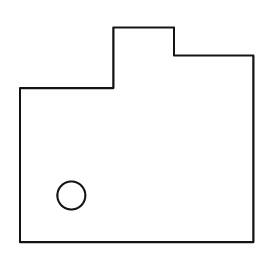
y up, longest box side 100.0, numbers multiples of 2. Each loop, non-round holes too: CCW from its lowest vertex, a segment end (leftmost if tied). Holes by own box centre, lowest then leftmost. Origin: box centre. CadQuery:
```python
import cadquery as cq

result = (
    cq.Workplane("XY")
    .moveTo(-50.0, -46.0)
    .lineTo(50.0, -46.0)
    .lineTo(50.0, 34.0)
    .lineTo(16.0, 34.0)
    .lineTo(16.0, 46.0)
    .lineTo(-10.0, 46.0)
    .lineTo(-10.0, 20.0)
    .lineTo(-50.0, 20.0)
    .close()
    .moveTo(-28.0, -26.0)
    .circle(6.0)
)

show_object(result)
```